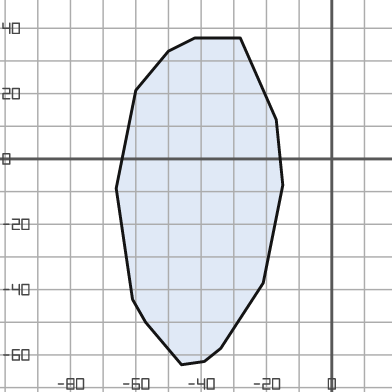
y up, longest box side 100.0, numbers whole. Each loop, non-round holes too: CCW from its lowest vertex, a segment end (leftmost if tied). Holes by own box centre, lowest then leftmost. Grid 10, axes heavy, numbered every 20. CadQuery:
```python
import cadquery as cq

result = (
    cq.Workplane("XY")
    .moveTo(-46.0, -63.0)
    .lineTo(-39.0, -62.0)
    .lineTo(-34.0, -58.0)
    .lineTo(-21.0, -38.0)
    .lineTo(-15.0, -8.0)
    .lineTo(-17.0, 12.0)
    .lineTo(-28.0, 37.0)
    .lineTo(-42.0, 37.0)
    .lineTo(-50.0, 33.0)
    .lineTo(-60.0, 21.0)
    .lineTo(-66.0, -9.0)
    .lineTo(-61.0, -43.0)
    .lineTo(-57.0, -50.0)
    .close()
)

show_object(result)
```